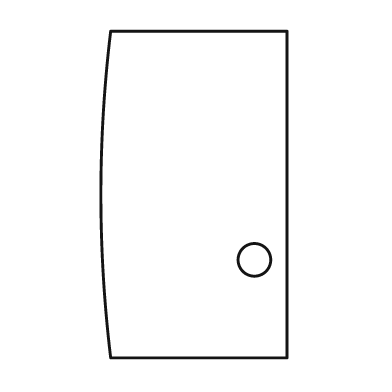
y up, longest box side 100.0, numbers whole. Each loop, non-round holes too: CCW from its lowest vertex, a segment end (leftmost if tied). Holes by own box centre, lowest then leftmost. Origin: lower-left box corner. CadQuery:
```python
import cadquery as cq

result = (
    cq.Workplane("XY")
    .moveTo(3.0, 0.0)
    .lineTo(57.0, 0.0)
    .lineTo(57.0, 100.0)
    .lineTo(3.0, 100.0)
    .threePointArc((0.0, 50.0), (3.0, 0.0))
    .close()
    .moveTo(47.0, 30.0)
    .circle(5.0)
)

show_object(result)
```